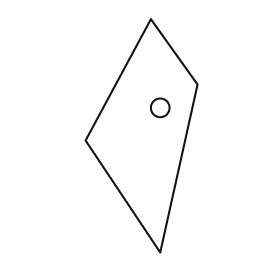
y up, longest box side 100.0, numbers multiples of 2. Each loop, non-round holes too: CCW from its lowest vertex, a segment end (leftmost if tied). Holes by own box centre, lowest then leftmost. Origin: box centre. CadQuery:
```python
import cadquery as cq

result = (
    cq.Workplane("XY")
    .moveTo(8.0, -50.0)
    .lineTo(24.0, 22.0)
    .lineTo(4.0, 50.0)
    .lineTo(-24.0, -2.0)
    .close()
    .moveTo(8.0, 12.0)
    .circle(4.0)
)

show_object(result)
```